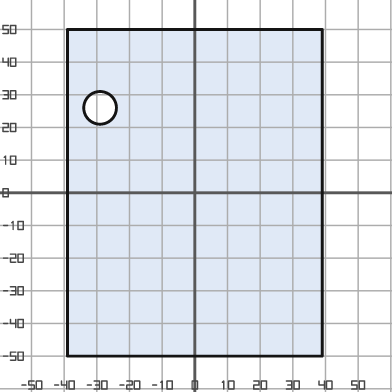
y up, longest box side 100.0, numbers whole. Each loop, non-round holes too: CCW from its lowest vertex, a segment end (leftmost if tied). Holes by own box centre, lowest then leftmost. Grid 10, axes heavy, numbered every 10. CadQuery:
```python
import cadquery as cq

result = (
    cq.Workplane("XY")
    .moveTo(-39.0, -50.0)
    .lineTo(39.0, -50.0)
    .lineTo(39.0, 50.0)
    .lineTo(-39.0, 50.0)
    .close()
    .moveTo(-29.0, 26.0)
    .circle(5.0)
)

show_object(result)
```